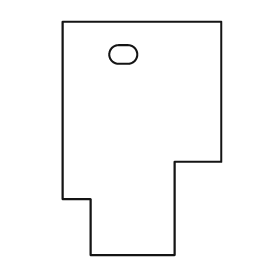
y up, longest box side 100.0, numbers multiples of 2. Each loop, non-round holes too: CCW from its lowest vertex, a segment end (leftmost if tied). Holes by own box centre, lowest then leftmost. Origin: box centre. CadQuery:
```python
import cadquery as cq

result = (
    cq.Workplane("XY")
    .moveTo(-22.0, -50.0)
    .lineTo(14.0, -50.0)
    .lineTo(14.0, -10.0)
    .lineTo(34.0, -10.0)
    .lineTo(34.0, 50.0)
    .lineTo(-34.0, 50.0)
    .lineTo(-34.0, -26.0)
    .lineTo(-22.0, -26.0)
    .close()
    .moveTo(-10.0, 32.0)
    .lineTo(-6.0, 32.0)
    .threePointArc((-2.0, 36.0), (-6.0, 40.0))
    .lineTo(-10.0, 40.0)
    .threePointArc((-14.0, 36.0), (-10.0, 32.0))
    .close()
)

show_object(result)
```